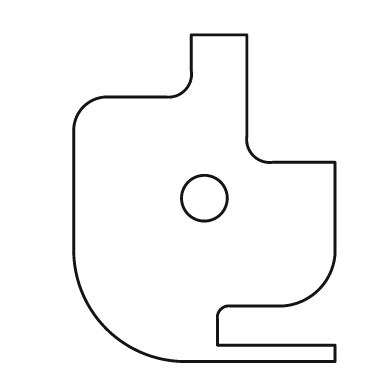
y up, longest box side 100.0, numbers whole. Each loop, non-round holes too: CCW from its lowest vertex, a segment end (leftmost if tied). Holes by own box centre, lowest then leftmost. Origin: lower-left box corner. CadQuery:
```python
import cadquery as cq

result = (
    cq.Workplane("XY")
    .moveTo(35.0, 0.0)
    .lineTo(80.0, 0.0)
    .lineTo(80.0, 5.0)
    .lineTo(44.0, 5.0)
    .lineTo(44.0, 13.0)
    .threePointArc((45.0, 16.0), (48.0, 17.0))
    .lineTo(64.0, 17.0)
    .threePointArc((75.0, 22.0), (80.0, 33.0))
    .lineTo(80.0, 61.0)
    .lineTo(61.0, 61.0)
    .threePointArc((55.0, 63.0), (53.0, 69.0))
    .lineTo(53.0, 100.0)
    .lineTo(36.0, 100.0)
    .lineTo(36.0, 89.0)
    .threePointArc((34.0, 83.0), (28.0, 81.0))
    .lineTo(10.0, 81.0)
    .threePointArc((3.0, 78.0), (0.0, 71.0))
    .lineTo(0.0, 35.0)
    .threePointArc((10.0, 10.0), (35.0, 0.0))
    .close()
    .moveTo(40.0, 50.0)
    .circle(7.0)
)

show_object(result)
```